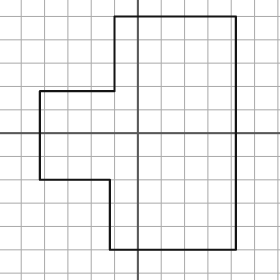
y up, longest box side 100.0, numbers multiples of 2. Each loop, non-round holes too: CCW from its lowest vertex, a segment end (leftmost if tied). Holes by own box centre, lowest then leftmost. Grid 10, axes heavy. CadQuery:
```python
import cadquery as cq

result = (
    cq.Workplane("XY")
    .moveTo(-12.0, -50.0)
    .lineTo(42.0, -50.0)
    .lineTo(42.0, 50.0)
    .lineTo(-10.0, 50.0)
    .lineTo(-10.0, 18.0)
    .lineTo(-42.0, 18.0)
    .lineTo(-42.0, -20.0)
    .lineTo(-12.0, -20.0)
    .close()
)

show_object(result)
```